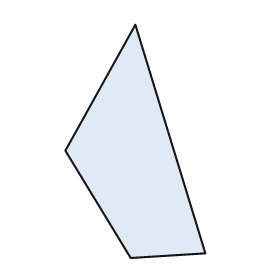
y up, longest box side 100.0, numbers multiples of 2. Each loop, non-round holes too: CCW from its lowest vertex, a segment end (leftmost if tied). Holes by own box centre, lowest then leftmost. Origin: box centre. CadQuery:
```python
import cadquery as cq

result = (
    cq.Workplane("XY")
    .moveTo(-2.0, -50.0)
    .lineTo(30.0, -48.0)
    .lineTo(0.0, 50.0)
    .lineTo(-30.0, -4.0)
    .close()
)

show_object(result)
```